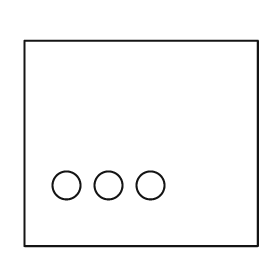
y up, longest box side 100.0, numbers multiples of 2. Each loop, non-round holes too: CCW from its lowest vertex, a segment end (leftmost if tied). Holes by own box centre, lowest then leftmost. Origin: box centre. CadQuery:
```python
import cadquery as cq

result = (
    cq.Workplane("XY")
    .moveTo(-50.0, -44.0)
    .lineTo(50.0, -44.0)
    .lineTo(50.0, 44.0)
    .lineTo(-50.0, 44.0)
    .close()
    .moveTo(-32.0, -18.0)
    .circle(6.0)
    .moveTo(-14.0, -18.0)
    .circle(6.0)
    .moveTo(4.0, -18.0)
    .circle(6.0)
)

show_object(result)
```